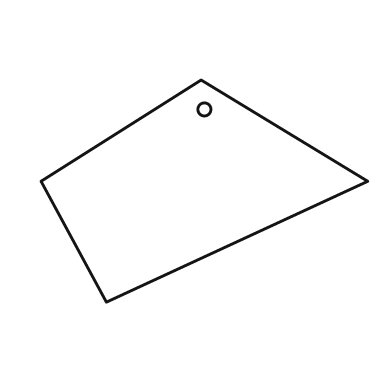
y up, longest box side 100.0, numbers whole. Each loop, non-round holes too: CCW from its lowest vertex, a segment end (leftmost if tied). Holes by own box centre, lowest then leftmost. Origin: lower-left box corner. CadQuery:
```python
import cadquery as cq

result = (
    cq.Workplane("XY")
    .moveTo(20.0, 0.0)
    .lineTo(100.0, 37.0)
    .lineTo(49.0, 68.0)
    .lineTo(0.0, 37.0)
    .close()
    .moveTo(50.0, 59.0)
    .circle(2.0)
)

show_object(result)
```